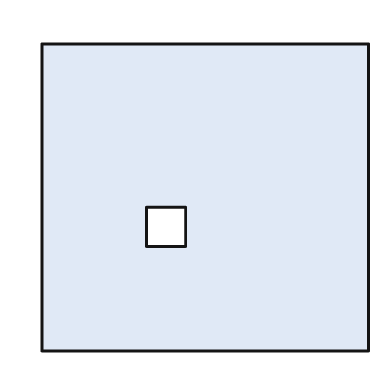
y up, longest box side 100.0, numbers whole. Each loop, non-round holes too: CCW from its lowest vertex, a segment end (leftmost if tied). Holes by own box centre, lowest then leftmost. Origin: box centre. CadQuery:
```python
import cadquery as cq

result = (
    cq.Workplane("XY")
    .moveTo(-50.0, -47.0)
    .lineTo(50.0, -47.0)
    .lineTo(50.0, 47.0)
    .lineTo(-50.0, 47.0)
    .close()
    .moveTo(-18.0, -15.0)
    .lineTo(-6.0, -15.0)
    .lineTo(-6.0, -3.0)
    .lineTo(-18.0, -3.0)
    .close()
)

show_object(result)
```